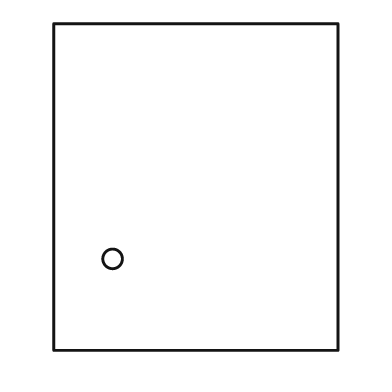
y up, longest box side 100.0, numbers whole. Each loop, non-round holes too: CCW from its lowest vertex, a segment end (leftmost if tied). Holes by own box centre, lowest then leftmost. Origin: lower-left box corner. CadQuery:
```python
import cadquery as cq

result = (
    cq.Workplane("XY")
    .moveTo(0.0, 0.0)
    .lineTo(87.0, 0.0)
    .lineTo(87.0, 100.0)
    .lineTo(0.0, 100.0)
    .close()
    .moveTo(18.0, 28.0)
    .circle(3.0)
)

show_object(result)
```